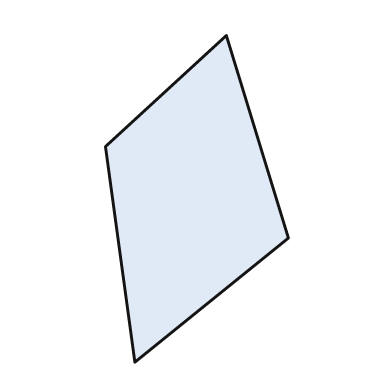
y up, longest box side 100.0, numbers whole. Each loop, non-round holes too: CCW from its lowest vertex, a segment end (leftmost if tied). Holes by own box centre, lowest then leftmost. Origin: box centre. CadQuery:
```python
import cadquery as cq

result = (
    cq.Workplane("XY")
    .moveTo(-19.0, -50.0)
    .lineTo(28.0, -12.0)
    .lineTo(9.0, 50.0)
    .lineTo(-28.0, 16.0)
    .close()
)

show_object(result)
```